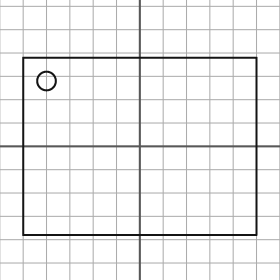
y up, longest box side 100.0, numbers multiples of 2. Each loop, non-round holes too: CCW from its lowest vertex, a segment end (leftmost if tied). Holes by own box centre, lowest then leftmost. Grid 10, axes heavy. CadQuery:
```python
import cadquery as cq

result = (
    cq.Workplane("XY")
    .moveTo(-50.0, -38.0)
    .lineTo(50.0, -38.0)
    .lineTo(50.0, 38.0)
    .lineTo(-50.0, 38.0)
    .close()
    .moveTo(-40.0, 28.0)
    .circle(4.0)
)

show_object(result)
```